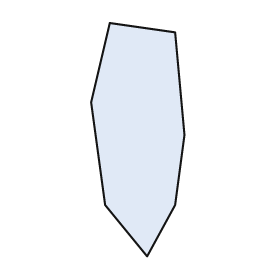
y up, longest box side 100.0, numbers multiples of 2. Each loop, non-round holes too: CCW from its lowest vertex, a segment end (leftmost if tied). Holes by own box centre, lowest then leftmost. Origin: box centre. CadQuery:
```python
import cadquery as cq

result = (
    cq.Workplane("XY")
    .moveTo(4.0, -50.0)
    .lineTo(16.0, -28.0)
    .lineTo(20.0, 2.0)
    .lineTo(16.0, 46.0)
    .lineTo(-12.0, 50.0)
    .lineTo(-20.0, 16.0)
    .lineTo(-14.0, -28.0)
    .close()
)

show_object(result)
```